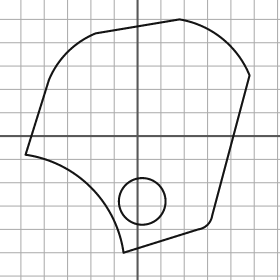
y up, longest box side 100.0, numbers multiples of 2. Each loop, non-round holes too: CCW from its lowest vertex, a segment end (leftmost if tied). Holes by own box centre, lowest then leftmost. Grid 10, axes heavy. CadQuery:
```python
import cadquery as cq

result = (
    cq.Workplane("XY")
    .moveTo(-6.0, -50.0)
    .lineTo(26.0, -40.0)
    .threePointArc((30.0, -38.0), (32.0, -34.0))
    .lineTo(48.0, 26.0)
    .threePointArc((36.0, 42.0), (18.0, 50.0))
    .lineTo(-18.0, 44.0)
    .threePointArc((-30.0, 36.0), (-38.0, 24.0))
    .lineTo(-48.0, -8.0)
    .threePointArc((-20.0, -22.0), (-6.0, -50.0))
    .close()
    .moveTo(2.0, -28.0)
    .circle(10.0)
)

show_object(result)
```